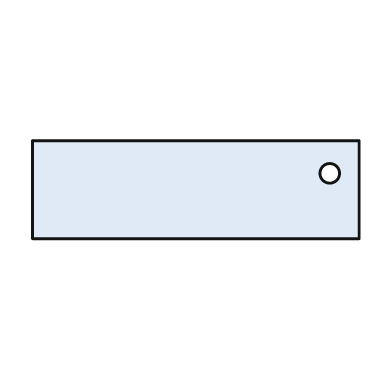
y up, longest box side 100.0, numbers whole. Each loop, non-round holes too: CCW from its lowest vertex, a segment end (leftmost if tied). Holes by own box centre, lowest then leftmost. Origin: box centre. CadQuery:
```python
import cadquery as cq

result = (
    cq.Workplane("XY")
    .moveTo(-50.0, -15.0)
    .lineTo(50.0, -15.0)
    .lineTo(50.0, 15.0)
    .lineTo(-50.0, 15.0)
    .close()
    .moveTo(41.0, 5.0)
    .circle(3.0)
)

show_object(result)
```